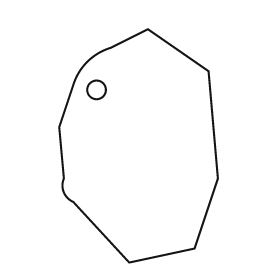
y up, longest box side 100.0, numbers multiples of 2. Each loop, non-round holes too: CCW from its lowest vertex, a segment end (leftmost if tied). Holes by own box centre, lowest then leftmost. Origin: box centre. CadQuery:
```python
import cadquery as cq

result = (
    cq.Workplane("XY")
    .moveTo(-4.0, -50.0)
    .lineTo(24.0, -44.0)
    .lineTo(34.0, -14.0)
    .lineTo(30.0, 32.0)
    .lineTo(4.0, 50.0)
    .lineTo(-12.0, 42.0)
    .threePointArc((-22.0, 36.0), (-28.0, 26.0))
    .lineTo(-34.0, 8.0)
    .lineTo(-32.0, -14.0)
    .threePointArc((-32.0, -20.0), (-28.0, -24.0))
    .close()
    .moveTo(-18.0, 24.0)
    .circle(4.0)
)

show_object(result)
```